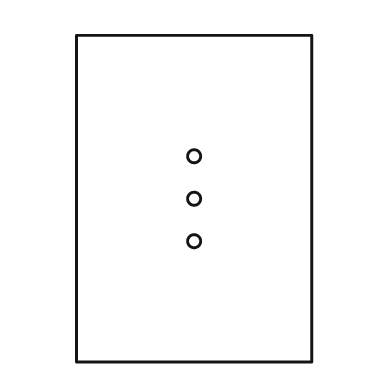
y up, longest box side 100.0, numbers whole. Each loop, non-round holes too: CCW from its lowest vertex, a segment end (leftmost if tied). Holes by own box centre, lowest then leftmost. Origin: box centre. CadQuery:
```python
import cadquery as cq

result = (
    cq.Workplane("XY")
    .moveTo(-36.0, -50.0)
    .lineTo(36.0, -50.0)
    .lineTo(36.0, 50.0)
    .lineTo(-36.0, 50.0)
    .close()
    .moveTo(0.0, -13.0)
    .circle(2.0)
    .moveTo(0.0, 0.0)
    .circle(2.0)
    .moveTo(0.0, 13.0)
    .circle(2.0)
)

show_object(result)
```